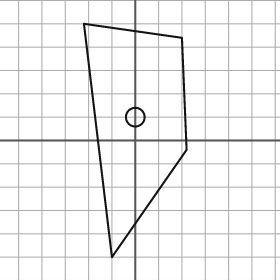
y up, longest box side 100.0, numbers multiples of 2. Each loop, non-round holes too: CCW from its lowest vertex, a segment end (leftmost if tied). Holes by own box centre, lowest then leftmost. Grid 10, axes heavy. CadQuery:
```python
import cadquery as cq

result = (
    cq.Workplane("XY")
    .moveTo(-10.0, -50.0)
    .lineTo(22.0, -4.0)
    .lineTo(20.0, 44.0)
    .lineTo(-22.0, 50.0)
    .close()
    .moveTo(0.0, 10.0)
    .circle(4.0)
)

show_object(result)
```